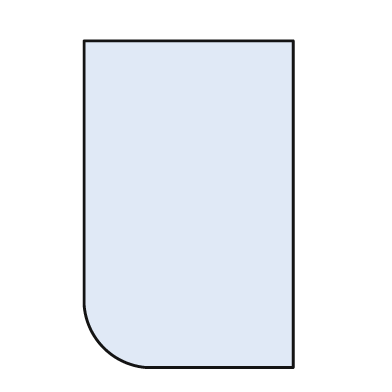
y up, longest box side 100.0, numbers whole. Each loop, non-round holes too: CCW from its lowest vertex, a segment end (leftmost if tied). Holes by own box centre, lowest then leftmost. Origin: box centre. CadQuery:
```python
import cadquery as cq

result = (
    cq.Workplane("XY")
    .moveTo(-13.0, -50.0)
    .lineTo(32.0, -50.0)
    .lineTo(32.0, 50.0)
    .lineTo(-32.0, 50.0)
    .lineTo(-32.0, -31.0)
    .threePointArc((-26.0, -44.0), (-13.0, -50.0))
    .close()
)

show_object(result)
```